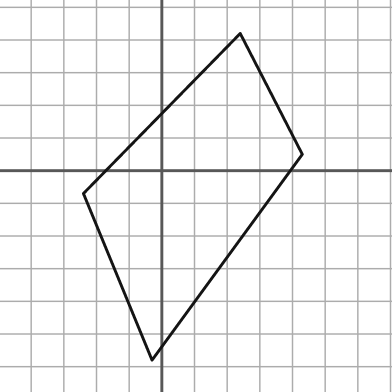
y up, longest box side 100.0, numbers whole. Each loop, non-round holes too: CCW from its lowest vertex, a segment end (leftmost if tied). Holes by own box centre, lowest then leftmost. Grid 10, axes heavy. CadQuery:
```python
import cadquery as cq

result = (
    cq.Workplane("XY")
    .moveTo(-3.0, -58.0)
    .lineTo(43.0, 5.0)
    .lineTo(24.0, 42.0)
    .lineTo(-24.0, -7.0)
    .close()
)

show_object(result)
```